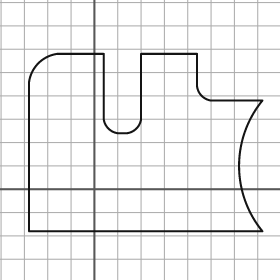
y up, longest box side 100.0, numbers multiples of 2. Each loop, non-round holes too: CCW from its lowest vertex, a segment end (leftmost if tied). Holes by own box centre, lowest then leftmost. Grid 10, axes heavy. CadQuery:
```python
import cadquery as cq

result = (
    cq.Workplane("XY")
    .moveTo(-28.0, -18.0)
    .lineTo(72.0, -18.0)
    .threePointArc((62.0, 10.0), (72.0, 38.0))
    .lineTo(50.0, 38.0)
    .threePointArc((46.0, 40.0), (44.0, 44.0))
    .lineTo(44.0, 58.0)
    .lineTo(20.0, 58.0)
    .lineTo(20.0, 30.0)
    .threePointArc((18.0, 26.0), (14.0, 24.0))
    .lineTo(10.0, 24.0)
    .threePointArc((6.0, 26.0), (4.0, 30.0))
    .lineTo(4.0, 58.0)
    .lineTo(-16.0, 58.0)
    .threePointArc((-24.0, 54.0), (-28.0, 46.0))
    .close()
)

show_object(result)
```